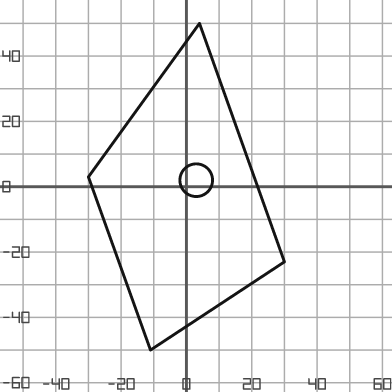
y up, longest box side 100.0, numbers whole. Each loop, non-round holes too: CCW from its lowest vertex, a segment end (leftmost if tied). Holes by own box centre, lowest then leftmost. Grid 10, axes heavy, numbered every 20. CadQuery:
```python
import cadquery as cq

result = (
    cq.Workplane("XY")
    .moveTo(-11.0, -50.0)
    .lineTo(30.0, -23.0)
    .lineTo(4.0, 50.0)
    .lineTo(-30.0, 3.0)
    .close()
    .moveTo(3.0, 2.0)
    .circle(5.0)
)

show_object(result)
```